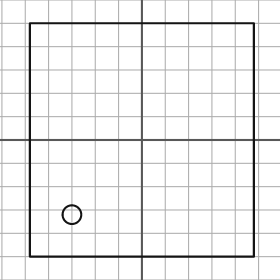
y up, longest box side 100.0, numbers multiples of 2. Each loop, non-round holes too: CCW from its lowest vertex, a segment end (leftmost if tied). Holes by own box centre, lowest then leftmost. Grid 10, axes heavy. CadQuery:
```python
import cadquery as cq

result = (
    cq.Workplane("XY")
    .moveTo(-48.0, -50.0)
    .lineTo(48.0, -50.0)
    .lineTo(48.0, 50.0)
    .lineTo(-48.0, 50.0)
    .close()
    .moveTo(-30.0, -32.0)
    .circle(4.0)
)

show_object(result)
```